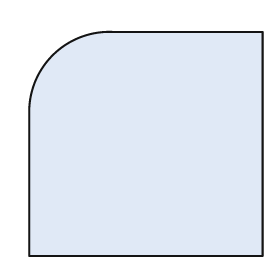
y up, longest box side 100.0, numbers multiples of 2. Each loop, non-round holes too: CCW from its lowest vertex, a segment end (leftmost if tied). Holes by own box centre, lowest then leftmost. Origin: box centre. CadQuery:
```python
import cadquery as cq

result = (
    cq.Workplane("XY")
    .moveTo(-50.0, -48.0)
    .lineTo(50.0, -48.0)
    .lineTo(50.0, 48.0)
    .lineTo(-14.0, 48.0)
    .threePointArc((-40.0, 38.0), (-50.0, 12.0))
    .close()
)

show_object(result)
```